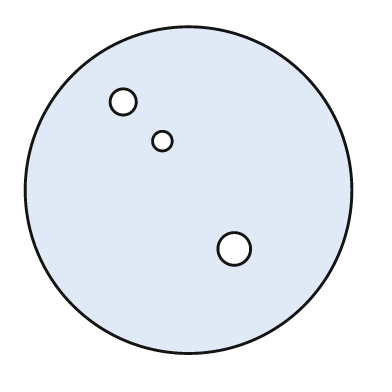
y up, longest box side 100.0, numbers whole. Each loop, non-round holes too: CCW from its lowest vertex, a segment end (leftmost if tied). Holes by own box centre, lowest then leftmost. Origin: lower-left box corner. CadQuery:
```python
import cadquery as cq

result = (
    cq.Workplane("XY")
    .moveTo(50.0, 50.0)
    .circle(50.0)
    .moveTo(64.0, 32.0)
    .circle(5.0)
    .moveTo(42.0, 65.0)
    .circle(3.0)
    .moveTo(30.0, 77.0)
    .circle(4.0)
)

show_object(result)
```